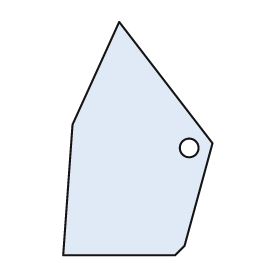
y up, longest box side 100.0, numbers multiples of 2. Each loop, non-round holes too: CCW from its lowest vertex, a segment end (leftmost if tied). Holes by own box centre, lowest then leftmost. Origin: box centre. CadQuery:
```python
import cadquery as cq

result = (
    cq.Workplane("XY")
    .moveTo(-32.0, -50.0)
    .lineTo(16.0, -50.0)
    .lineTo(20.0, -46.0)
    .lineTo(32.0, -2.0)
    .lineTo(-8.0, 50.0)
    .lineTo(-28.0, 6.0)
    .close()
    .moveTo(22.0, -4.0)
    .circle(4.0)
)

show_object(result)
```